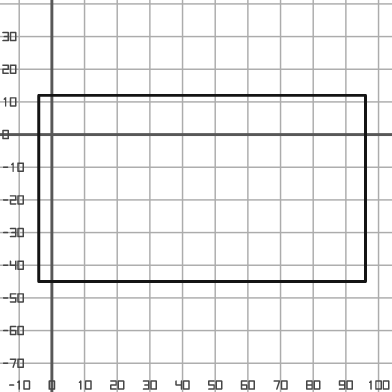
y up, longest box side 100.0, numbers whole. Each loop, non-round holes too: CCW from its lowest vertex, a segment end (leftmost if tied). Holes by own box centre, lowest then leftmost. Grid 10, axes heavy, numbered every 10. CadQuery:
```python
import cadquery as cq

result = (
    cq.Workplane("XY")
    .moveTo(-4.0, -45.0)
    .lineTo(96.0, -45.0)
    .lineTo(96.0, 12.0)
    .lineTo(-4.0, 12.0)
    .close()
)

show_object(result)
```